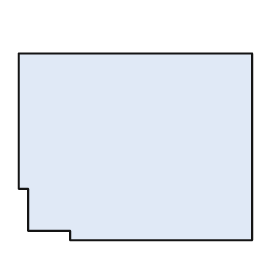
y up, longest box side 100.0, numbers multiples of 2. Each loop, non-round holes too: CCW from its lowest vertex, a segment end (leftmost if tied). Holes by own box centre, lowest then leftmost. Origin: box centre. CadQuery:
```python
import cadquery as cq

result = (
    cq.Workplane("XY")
    .moveTo(-28.0, -40.0)
    .lineTo(50.0, -40.0)
    .lineTo(50.0, 40.0)
    .lineTo(-50.0, 40.0)
    .lineTo(-50.0, -18.0)
    .lineTo(-46.0, -18.0)
    .lineTo(-46.0, -36.0)
    .lineTo(-28.0, -36.0)
    .close()
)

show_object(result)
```